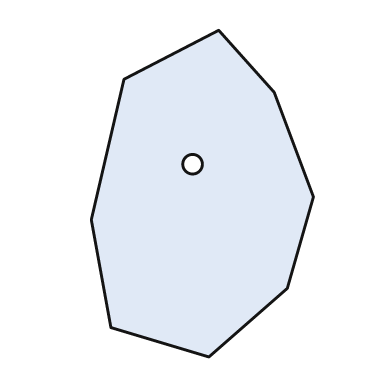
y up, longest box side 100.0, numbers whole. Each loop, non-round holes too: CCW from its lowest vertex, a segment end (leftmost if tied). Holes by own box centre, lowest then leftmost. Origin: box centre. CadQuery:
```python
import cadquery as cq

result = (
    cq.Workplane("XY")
    .moveTo(2.0, -50.0)
    .lineTo(26.0, -29.0)
    .lineTo(34.0, -1.0)
    .lineTo(22.0, 31.0)
    .lineTo(5.0, 50.0)
    .lineTo(-24.0, 35.0)
    .lineTo(-34.0, -8.0)
    .lineTo(-28.0, -41.0)
    .close()
    .moveTo(-3.0, 9.0)
    .circle(3.0)
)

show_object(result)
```